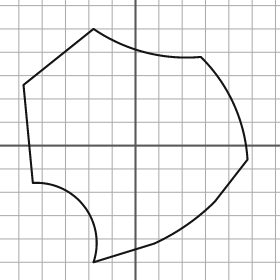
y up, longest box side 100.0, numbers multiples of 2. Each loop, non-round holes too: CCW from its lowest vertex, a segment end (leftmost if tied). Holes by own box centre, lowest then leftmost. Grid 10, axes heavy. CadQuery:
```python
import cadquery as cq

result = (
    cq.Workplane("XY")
    .moveTo(-18.0, -50.0)
    .lineTo(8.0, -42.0)
    .threePointArc((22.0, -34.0), (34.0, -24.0))
    .lineTo(48.0, -6.0)
    .threePointArc((42.0, 18.0), (28.0, 38.0))
    .threePointArc((4.0, 40.0), (-18.0, 50.0))
    .lineTo(-48.0, 26.0)
    .lineTo(-44.0, -16.0)
    .threePointArc((-22.0, -26.0), (-18.0, -50.0))
    .close()
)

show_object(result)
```